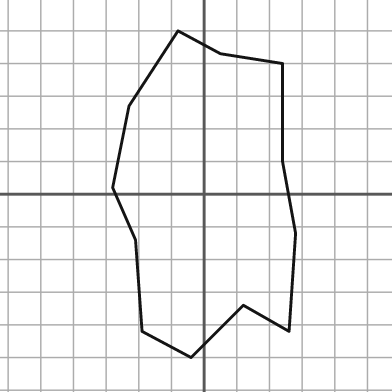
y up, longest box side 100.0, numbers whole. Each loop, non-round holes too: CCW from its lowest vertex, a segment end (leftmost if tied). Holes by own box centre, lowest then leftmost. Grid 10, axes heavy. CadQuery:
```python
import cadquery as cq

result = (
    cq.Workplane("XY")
    .moveTo(-4.0, -50.0)
    .lineTo(12.0, -34.0)
    .lineTo(26.0, -42.0)
    .lineTo(28.0, -12.0)
    .lineTo(24.0, 10.0)
    .lineTo(24.0, 40.0)
    .lineTo(5.0, 43.0)
    .lineTo(-8.0, 50.0)
    .lineTo(-23.0, 27.0)
    .lineTo(-28.0, 2.0)
    .lineTo(-21.0, -14.0)
    .lineTo(-19.0, -42.0)
    .close()
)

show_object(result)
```